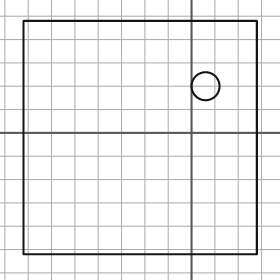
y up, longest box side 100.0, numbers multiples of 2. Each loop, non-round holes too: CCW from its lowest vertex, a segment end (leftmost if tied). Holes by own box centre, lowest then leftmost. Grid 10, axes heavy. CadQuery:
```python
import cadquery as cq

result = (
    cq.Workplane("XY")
    .moveTo(-72.0, -52.0)
    .lineTo(28.0, -52.0)
    .lineTo(28.0, 48.0)
    .lineTo(-72.0, 48.0)
    .close()
    .moveTo(6.0, 20.0)
    .circle(6.0)
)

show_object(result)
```